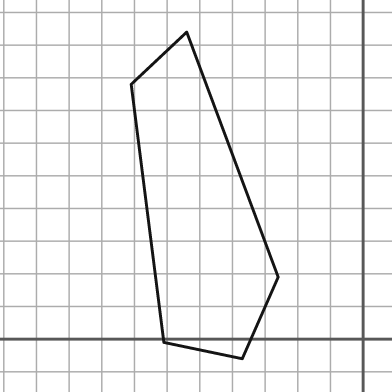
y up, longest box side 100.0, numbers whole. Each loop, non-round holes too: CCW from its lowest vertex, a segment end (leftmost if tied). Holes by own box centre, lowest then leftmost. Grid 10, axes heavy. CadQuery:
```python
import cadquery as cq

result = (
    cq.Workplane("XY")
    .moveTo(-37.0, -6.0)
    .lineTo(-26.0, 19.0)
    .lineTo(-54.0, 94.0)
    .lineTo(-71.0, 78.0)
    .lineTo(-61.0, -1.0)
    .close()
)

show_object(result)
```